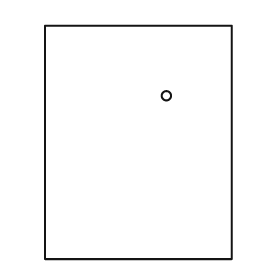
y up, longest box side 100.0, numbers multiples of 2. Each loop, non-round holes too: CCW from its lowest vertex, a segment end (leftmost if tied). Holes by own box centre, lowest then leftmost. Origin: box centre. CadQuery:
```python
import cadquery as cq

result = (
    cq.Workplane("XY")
    .moveTo(-40.0, -50.0)
    .lineTo(40.0, -50.0)
    .lineTo(40.0, 50.0)
    .lineTo(-40.0, 50.0)
    .close()
    .moveTo(12.0, 20.0)
    .circle(2.0)
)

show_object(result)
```